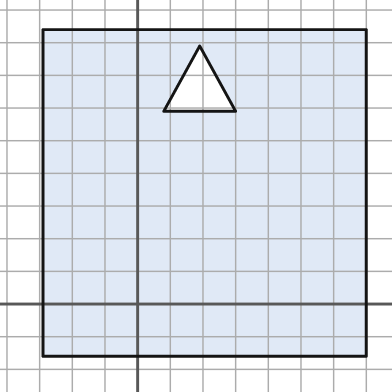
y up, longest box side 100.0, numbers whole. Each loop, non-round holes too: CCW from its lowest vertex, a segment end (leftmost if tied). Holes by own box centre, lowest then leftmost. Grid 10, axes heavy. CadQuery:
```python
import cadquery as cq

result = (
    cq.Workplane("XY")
    .moveTo(-29.0, -16.0)
    .lineTo(70.0, -16.0)
    .lineTo(70.0, 84.0)
    .lineTo(-29.0, 84.0)
    .close()
    .moveTo(8.0, 59.0)
    .lineTo(30.0, 59.0)
    .lineTo(19.0, 79.0)
    .close()
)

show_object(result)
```